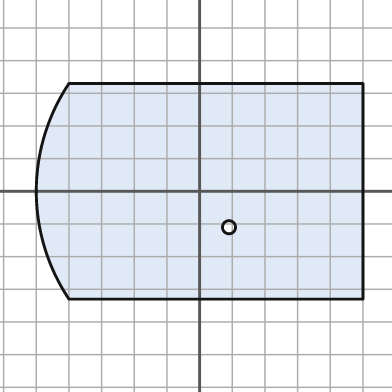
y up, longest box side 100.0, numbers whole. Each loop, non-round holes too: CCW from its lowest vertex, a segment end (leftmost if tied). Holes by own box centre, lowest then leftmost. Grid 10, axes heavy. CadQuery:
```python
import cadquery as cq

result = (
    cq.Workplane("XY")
    .moveTo(-40.0, -33.0)
    .lineTo(50.0, -33.0)
    .lineTo(50.0, 33.0)
    .lineTo(-40.0, 33.0)
    .threePointArc((-50.0, 0.0), (-40.0, -33.0))
    .close()
    .moveTo(9.0, -11.0)
    .circle(2.0)
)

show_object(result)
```